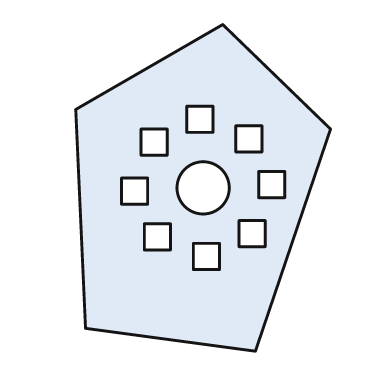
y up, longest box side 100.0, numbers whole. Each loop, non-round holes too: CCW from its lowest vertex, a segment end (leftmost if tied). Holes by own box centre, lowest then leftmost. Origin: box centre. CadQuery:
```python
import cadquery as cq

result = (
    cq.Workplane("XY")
    .moveTo(16.0, -50.0)
    .lineTo(39.0, 18.0)
    .lineTo(6.0, 50.0)
    .lineTo(-39.0, 24.0)
    .lineTo(-36.0, -43.0)
    .close()
    .moveTo(-3.0, -25.0)
    .lineTo(5.0, -25.0)
    .lineTo(5.0, -17.0)
    .lineTo(-3.0, -17.0)
    .close()
    .moveTo(-18.0, -19.0)
    .lineTo(-10.0, -19.0)
    .lineTo(-10.0, -11.0)
    .lineTo(-18.0, -11.0)
    .close()
    .moveTo(11.0, -18.0)
    .lineTo(19.0, -18.0)
    .lineTo(19.0, -10.0)
    .lineTo(11.0, -10.0)
    .close()
    .moveTo(-25.0, -5.0)
    .lineTo(-17.0, -5.0)
    .lineTo(-17.0, 3.0)
    .lineTo(-25.0, 3.0)
    .close()
    .moveTo(0.0, 0.0)
    .circle(8.0)
    .moveTo(17.0, -3.0)
    .lineTo(25.0, -3.0)
    .lineTo(25.0, 5.0)
    .lineTo(17.0, 5.0)
    .close()
    .moveTo(-19.0, 10.0)
    .lineTo(-11.0, 10.0)
    .lineTo(-11.0, 18.0)
    .lineTo(-19.0, 18.0)
    .close()
    .moveTo(10.0, 11.0)
    .lineTo(18.0, 11.0)
    .lineTo(18.0, 19.0)
    .lineTo(10.0, 19.0)
    .close()
    .moveTo(-5.0, 17.0)
    .lineTo(3.0, 17.0)
    .lineTo(3.0, 25.0)
    .lineTo(-5.0, 25.0)
    .close()
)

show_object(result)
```